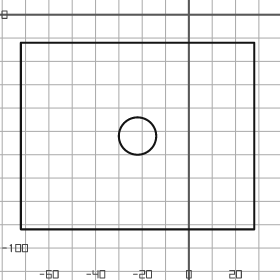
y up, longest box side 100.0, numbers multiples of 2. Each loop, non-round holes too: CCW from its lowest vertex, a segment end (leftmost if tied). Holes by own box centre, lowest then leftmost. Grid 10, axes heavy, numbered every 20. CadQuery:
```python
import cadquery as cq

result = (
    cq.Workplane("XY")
    .moveTo(-72.0, -92.0)
    .lineTo(28.0, -92.0)
    .lineTo(28.0, -12.0)
    .lineTo(-72.0, -12.0)
    .close()
    .moveTo(-22.0, -52.0)
    .circle(8.0)
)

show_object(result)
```